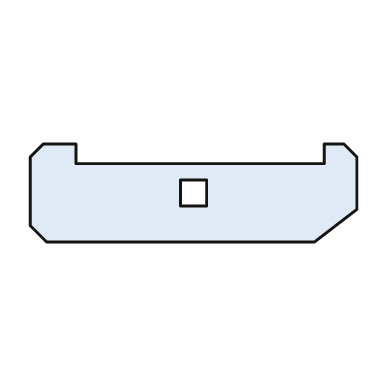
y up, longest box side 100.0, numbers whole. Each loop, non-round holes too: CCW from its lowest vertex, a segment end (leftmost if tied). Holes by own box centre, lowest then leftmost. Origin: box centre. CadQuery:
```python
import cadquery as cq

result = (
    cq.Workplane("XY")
    .moveTo(-45.0, -15.0)
    .lineTo(37.0, -15.0)
    .lineTo(50.0, -5.0)
    .lineTo(50.0, 11.0)
    .lineTo(46.0, 15.0)
    .lineTo(40.0, 15.0)
    .lineTo(40.0, 9.0)
    .lineTo(-36.0, 9.0)
    .lineTo(-36.0, 15.0)
    .lineTo(-46.0, 15.0)
    .lineTo(-50.0, 11.0)
    .lineTo(-50.0, -10.0)
    .close()
    .moveTo(-4.0, -4.0)
    .lineTo(4.0, -4.0)
    .lineTo(4.0, 4.0)
    .lineTo(-4.0, 4.0)
    .close()
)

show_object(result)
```